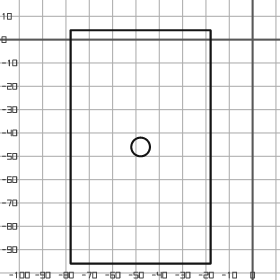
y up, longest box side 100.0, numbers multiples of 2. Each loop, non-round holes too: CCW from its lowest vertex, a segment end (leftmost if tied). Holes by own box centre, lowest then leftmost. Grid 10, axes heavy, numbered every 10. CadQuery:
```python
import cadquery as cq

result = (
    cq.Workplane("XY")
    .moveTo(-78.0, -96.0)
    .lineTo(-18.0, -96.0)
    .lineTo(-18.0, 4.0)
    .lineTo(-78.0, 4.0)
    .close()
    .moveTo(-48.0, -46.0)
    .circle(4.0)
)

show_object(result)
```